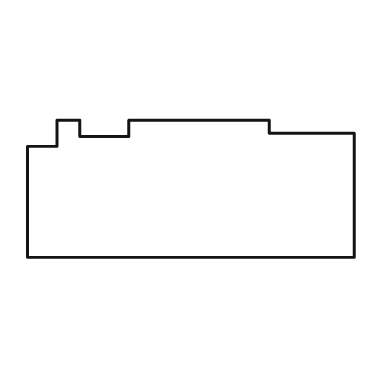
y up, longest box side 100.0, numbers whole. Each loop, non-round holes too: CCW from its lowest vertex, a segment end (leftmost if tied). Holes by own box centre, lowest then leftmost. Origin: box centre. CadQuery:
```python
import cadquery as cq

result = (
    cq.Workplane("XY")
    .moveTo(-50.0, -21.0)
    .lineTo(50.0, -21.0)
    .lineTo(50.0, 17.0)
    .lineTo(24.0, 17.0)
    .lineTo(24.0, 21.0)
    .lineTo(-19.0, 21.0)
    .lineTo(-19.0, 16.0)
    .lineTo(-34.0, 16.0)
    .lineTo(-34.0, 21.0)
    .lineTo(-41.0, 21.0)
    .lineTo(-41.0, 13.0)
    .lineTo(-50.0, 13.0)
    .close()
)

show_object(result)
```